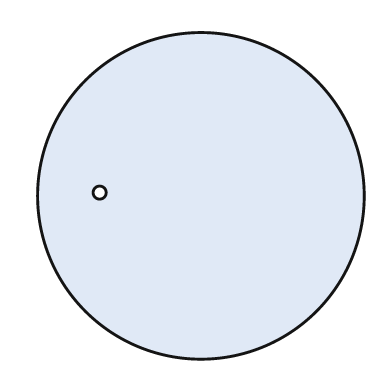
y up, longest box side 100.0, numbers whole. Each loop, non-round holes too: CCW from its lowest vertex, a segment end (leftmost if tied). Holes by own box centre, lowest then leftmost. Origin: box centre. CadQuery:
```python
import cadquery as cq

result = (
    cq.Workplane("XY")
    .moveTo(0.0, 0.0)
    .circle(50.0)
    .moveTo(-31.0, 1.0)
    .circle(2.0)
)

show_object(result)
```